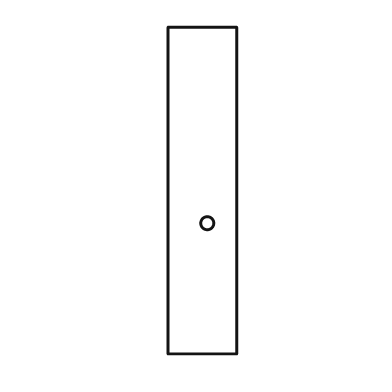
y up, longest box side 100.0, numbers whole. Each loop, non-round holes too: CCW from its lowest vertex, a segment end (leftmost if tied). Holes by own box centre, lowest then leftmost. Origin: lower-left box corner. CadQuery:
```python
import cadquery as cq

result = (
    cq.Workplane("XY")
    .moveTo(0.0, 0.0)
    .lineTo(21.0, 0.0)
    .lineTo(21.0, 100.0)
    .lineTo(0.0, 100.0)
    .close()
    .moveTo(12.0, 40.0)
    .circle(2.0)
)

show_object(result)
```